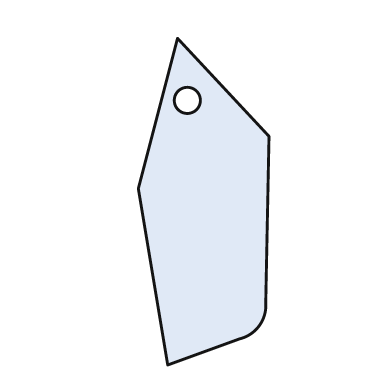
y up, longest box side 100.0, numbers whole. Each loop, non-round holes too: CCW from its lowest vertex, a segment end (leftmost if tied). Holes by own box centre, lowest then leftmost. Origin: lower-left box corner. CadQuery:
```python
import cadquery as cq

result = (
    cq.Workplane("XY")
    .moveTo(9.0, 0.0)
    .lineTo(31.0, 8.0)
    .threePointArc((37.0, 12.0), (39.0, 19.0))
    .lineTo(40.0, 70.0)
    .lineTo(12.0, 100.0)
    .lineTo(0.0, 54.0)
    .close()
    .moveTo(15.0, 81.0)
    .circle(4.0)
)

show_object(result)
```